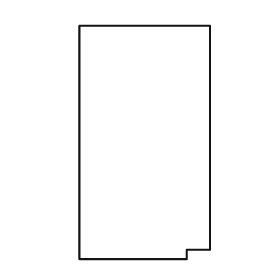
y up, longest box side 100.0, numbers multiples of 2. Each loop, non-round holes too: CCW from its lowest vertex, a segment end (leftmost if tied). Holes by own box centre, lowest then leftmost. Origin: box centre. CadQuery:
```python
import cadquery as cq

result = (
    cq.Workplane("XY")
    .moveTo(-28.0, -50.0)
    .lineTo(18.0, -50.0)
    .lineTo(18.0, -46.0)
    .lineTo(28.0, -46.0)
    .lineTo(28.0, 50.0)
    .lineTo(-28.0, 50.0)
    .close()
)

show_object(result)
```